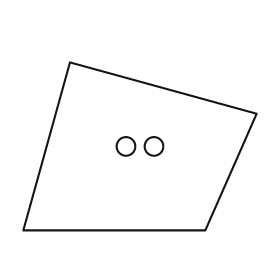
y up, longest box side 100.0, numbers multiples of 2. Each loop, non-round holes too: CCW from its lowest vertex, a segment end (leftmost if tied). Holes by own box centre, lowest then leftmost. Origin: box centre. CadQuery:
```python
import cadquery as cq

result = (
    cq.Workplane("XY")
    .moveTo(-50.0, -36.0)
    .lineTo(28.0, -36.0)
    .lineTo(50.0, 14.0)
    .lineTo(-30.0, 36.0)
    .close()
    .moveTo(-6.0, 0.0)
    .circle(4.0)
    .moveTo(6.0, 0.0)
    .circle(4.0)
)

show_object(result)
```